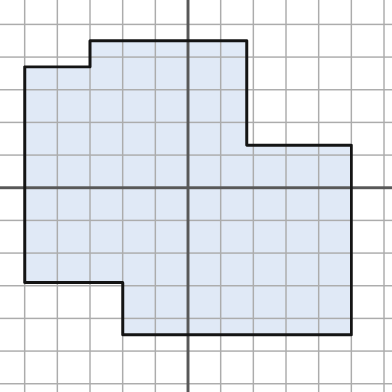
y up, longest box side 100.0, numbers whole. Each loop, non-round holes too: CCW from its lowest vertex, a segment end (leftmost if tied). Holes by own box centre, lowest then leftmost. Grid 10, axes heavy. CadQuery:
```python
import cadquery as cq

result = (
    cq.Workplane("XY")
    .moveTo(-20.0, -45.0)
    .lineTo(50.0, -45.0)
    .lineTo(50.0, 13.0)
    .lineTo(18.0, 13.0)
    .lineTo(18.0, 45.0)
    .lineTo(-30.0, 45.0)
    .lineTo(-30.0, 37.0)
    .lineTo(-50.0, 37.0)
    .lineTo(-50.0, -29.0)
    .lineTo(-20.0, -29.0)
    .close()
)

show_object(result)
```